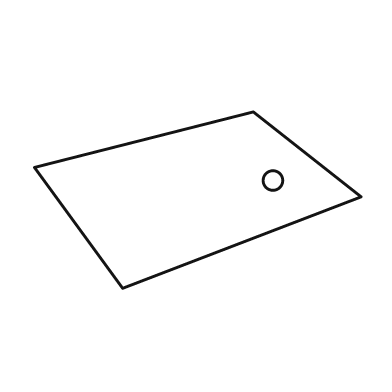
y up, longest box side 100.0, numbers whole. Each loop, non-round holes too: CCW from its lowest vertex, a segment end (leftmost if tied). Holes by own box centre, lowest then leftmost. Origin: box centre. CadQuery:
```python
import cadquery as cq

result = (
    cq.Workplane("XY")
    .moveTo(-23.0, -27.0)
    .lineTo(50.0, 1.0)
    .lineTo(17.0, 27.0)
    .lineTo(-50.0, 10.0)
    .close()
    .moveTo(23.0, 6.0)
    .circle(3.0)
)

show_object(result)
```